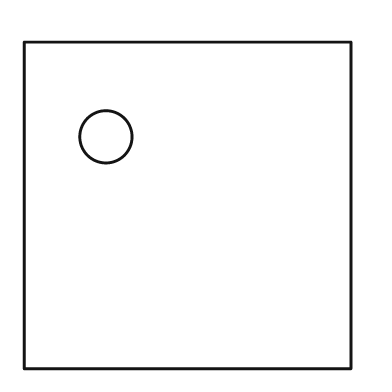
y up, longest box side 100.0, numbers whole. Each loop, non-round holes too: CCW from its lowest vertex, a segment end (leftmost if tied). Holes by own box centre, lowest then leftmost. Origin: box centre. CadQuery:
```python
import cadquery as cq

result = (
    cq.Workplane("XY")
    .moveTo(-50.0, -50.0)
    .lineTo(50.0, -50.0)
    .lineTo(50.0, 50.0)
    .lineTo(-50.0, 50.0)
    .close()
    .moveTo(-25.0, 21.0)
    .circle(8.0)
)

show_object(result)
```